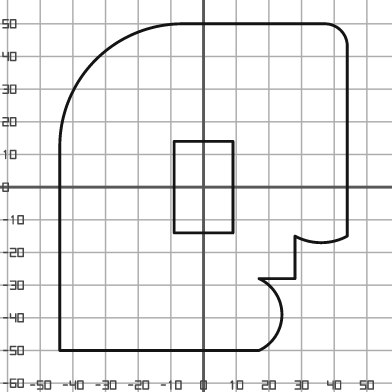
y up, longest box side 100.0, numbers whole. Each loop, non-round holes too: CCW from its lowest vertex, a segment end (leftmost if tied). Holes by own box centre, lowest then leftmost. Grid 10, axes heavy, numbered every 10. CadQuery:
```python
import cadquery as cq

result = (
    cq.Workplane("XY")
    .moveTo(-44.0, -50.0)
    .lineTo(17.0, -50.0)
    .threePointArc((24.0, -39.0), (17.0, -28.0))
    .lineTo(28.0, -28.0)
    .lineTo(28.0, -15.0)
    .threePointArc((36.0, -17.0), (44.0, -15.0))
    .lineTo(44.0, 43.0)
    .threePointArc((42.0, 48.0), (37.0, 50.0))
    .lineTo(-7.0, 50.0)
    .threePointArc((-33.0, 39.0), (-44.0, 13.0))
    .close()
    .moveTo(-9.0, -14.0)
    .lineTo(9.0, -14.0)
    .lineTo(9.0, 14.0)
    .lineTo(-9.0, 14.0)
    .close()
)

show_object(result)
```